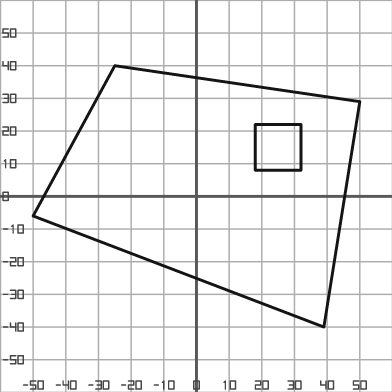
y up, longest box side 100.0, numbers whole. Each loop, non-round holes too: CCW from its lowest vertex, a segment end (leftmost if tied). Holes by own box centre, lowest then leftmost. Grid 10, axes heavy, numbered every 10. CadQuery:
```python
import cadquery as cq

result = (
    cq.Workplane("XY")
    .moveTo(39.0, -40.0)
    .lineTo(50.0, 29.0)
    .lineTo(-25.0, 40.0)
    .lineTo(-50.0, -6.0)
    .close()
    .moveTo(18.0, 8.0)
    .lineTo(32.0, 8.0)
    .lineTo(32.0, 22.0)
    .lineTo(18.0, 22.0)
    .close()
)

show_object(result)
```